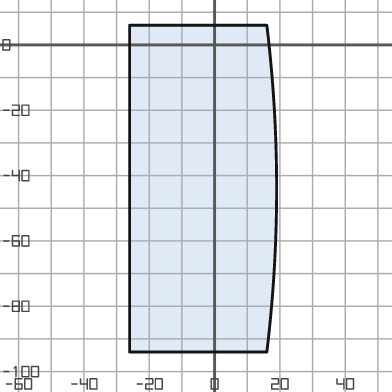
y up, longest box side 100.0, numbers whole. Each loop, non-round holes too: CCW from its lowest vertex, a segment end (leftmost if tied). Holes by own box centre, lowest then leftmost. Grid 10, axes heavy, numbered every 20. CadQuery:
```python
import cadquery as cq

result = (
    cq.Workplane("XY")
    .moveTo(-26.0, -94.0)
    .lineTo(16.0, -94.0)
    .threePointArc((19.0, -44.0), (16.0, 6.0))
    .lineTo(-26.0, 6.0)
    .close()
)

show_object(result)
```